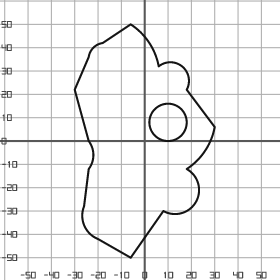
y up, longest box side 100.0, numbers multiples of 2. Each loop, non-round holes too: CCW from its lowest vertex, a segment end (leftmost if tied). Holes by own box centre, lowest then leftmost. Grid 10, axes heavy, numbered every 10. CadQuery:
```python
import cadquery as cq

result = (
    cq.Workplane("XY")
    .moveTo(-6.0, -50.0)
    .lineTo(8.0, -30.0)
    .threePointArc((22.0, -26.0), (18.0, -12.0))
    .threePointArc((26.0, -4.0), (30.0, 6.0))
    .lineTo(18.0, 22.0)
    .threePointArc((16.0, 32.0), (6.0, 32.0))
    .threePointArc((2.0, 42.0), (-6.0, 50.0))
    .lineTo(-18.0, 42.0)
    .threePointArc((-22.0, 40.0), (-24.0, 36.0))
    .lineTo(-30.0, 22.0)
    .lineTo(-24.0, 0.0)
    .threePointArc((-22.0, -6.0), (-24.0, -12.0))
    .lineTo(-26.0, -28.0)
    .threePointArc((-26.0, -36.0), (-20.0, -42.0))
    .close()
    .moveTo(10.0, 8.0)
    .circle(8.0)
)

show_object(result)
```